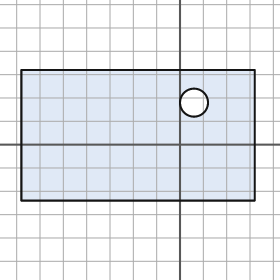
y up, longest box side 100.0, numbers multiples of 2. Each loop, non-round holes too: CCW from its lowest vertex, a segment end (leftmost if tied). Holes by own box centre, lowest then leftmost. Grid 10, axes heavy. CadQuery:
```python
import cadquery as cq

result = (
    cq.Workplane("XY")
    .moveTo(-68.0, -24.0)
    .lineTo(32.0, -24.0)
    .lineTo(32.0, 32.0)
    .lineTo(-68.0, 32.0)
    .close()
    .moveTo(6.0, 18.0)
    .circle(6.0)
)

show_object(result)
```